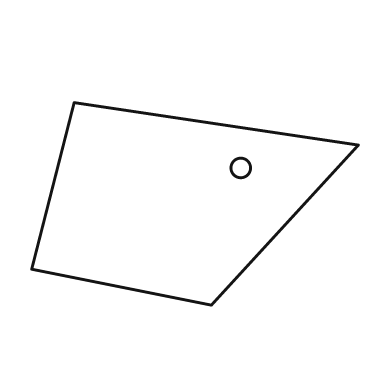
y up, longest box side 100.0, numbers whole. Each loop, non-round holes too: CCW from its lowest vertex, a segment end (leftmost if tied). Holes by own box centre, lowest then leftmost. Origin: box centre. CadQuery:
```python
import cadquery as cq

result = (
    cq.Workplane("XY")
    .moveTo(5.0, -31.0)
    .lineTo(50.0, 18.0)
    .lineTo(-37.0, 31.0)
    .lineTo(-50.0, -20.0)
    .close()
    .moveTo(14.0, 11.0)
    .circle(3.0)
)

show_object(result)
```